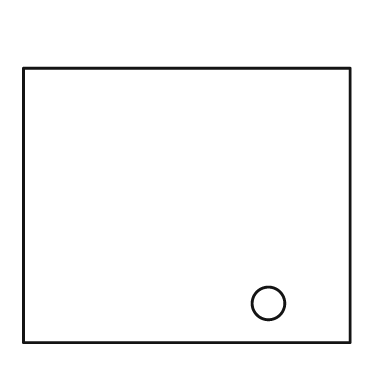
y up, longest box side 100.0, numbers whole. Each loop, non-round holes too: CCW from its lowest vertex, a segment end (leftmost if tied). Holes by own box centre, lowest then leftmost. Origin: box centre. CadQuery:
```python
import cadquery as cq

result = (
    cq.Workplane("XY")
    .moveTo(-50.0, -42.0)
    .lineTo(50.0, -42.0)
    .lineTo(50.0, 42.0)
    .lineTo(-50.0, 42.0)
    .close()
    .moveTo(25.0, -30.0)
    .circle(5.0)
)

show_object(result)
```